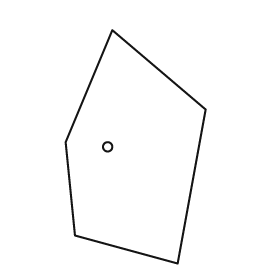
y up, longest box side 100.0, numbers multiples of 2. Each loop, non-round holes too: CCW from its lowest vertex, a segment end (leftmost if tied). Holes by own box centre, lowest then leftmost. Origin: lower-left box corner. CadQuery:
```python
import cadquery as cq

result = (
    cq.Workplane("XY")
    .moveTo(48.0, 0.0)
    .lineTo(60.0, 66.0)
    .lineTo(20.0, 100.0)
    .lineTo(0.0, 52.0)
    .lineTo(4.0, 12.0)
    .close()
    .moveTo(18.0, 50.0)
    .circle(2.0)
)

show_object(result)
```